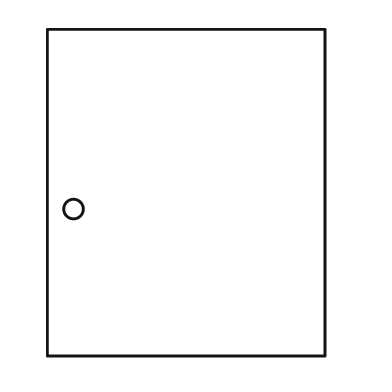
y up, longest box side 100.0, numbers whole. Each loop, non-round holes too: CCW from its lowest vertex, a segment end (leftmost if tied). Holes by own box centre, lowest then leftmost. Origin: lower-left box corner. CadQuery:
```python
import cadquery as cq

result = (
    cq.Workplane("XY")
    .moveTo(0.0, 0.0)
    .lineTo(85.0, 0.0)
    .lineTo(85.0, 100.0)
    .lineTo(0.0, 100.0)
    .close()
    .moveTo(8.0, 45.0)
    .circle(3.0)
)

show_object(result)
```